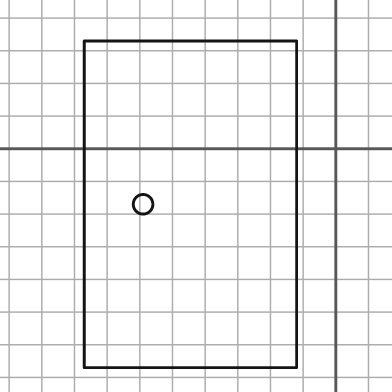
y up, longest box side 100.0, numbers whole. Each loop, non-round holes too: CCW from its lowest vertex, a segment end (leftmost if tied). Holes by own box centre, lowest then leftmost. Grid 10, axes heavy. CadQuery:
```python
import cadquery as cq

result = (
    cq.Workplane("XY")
    .moveTo(-77.0, -67.0)
    .lineTo(-12.0, -67.0)
    .lineTo(-12.0, 33.0)
    .lineTo(-77.0, 33.0)
    .close()
    .moveTo(-59.0, -17.0)
    .circle(3.0)
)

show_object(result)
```